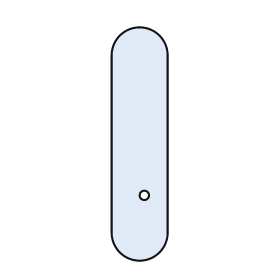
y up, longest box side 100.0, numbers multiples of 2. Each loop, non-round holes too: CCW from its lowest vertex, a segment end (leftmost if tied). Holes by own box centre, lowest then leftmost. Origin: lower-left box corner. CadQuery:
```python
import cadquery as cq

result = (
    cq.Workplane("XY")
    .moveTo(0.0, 12.0)
    .threePointArc((12.0, 0.0), (24.0, 12.0))
    .lineTo(24.0, 88.0)
    .threePointArc((12.0, 100.0), (0.0, 88.0))
    .close()
    .moveTo(14.0, 28.0)
    .circle(2.0)
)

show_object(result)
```